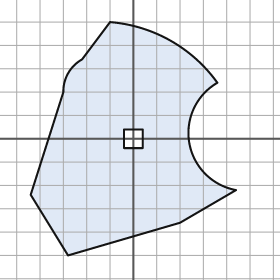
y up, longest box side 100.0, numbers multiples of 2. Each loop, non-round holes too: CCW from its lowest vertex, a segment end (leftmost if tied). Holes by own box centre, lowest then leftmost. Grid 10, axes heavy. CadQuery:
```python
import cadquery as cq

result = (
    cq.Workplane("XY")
    .moveTo(-28.0, -50.0)
    .lineTo(20.0, -36.0)
    .lineTo(44.0, -22.0)
    .threePointArc((24.0, -2.0), (36.0, 24.0))
    .threePointArc((16.0, 42.0), (-10.0, 50.0))
    .lineTo(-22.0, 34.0)
    .threePointArc((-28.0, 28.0), (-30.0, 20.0))
    .lineTo(-44.0, -24.0)
    .close()
    .moveTo(-4.0, -4.0)
    .lineTo(4.0, -4.0)
    .lineTo(4.0, 4.0)
    .lineTo(-4.0, 4.0)
    .close()
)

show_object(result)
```